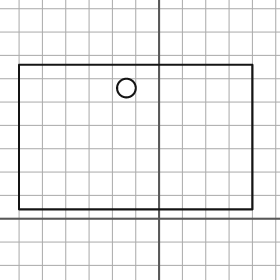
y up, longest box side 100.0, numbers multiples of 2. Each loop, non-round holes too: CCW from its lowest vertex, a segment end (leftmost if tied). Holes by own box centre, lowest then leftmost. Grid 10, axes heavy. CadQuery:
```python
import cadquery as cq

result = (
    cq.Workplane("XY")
    .moveTo(-60.0, 4.0)
    .lineTo(40.0, 4.0)
    .lineTo(40.0, 66.0)
    .lineTo(-60.0, 66.0)
    .close()
    .moveTo(-14.0, 56.0)
    .circle(4.0)
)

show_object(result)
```